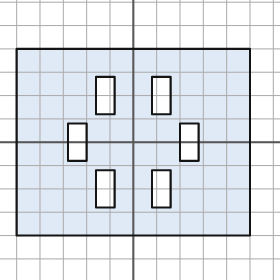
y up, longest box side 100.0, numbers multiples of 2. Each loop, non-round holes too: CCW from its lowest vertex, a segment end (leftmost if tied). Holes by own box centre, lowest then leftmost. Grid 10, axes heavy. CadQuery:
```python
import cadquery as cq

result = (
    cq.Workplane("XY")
    .moveTo(-50.0, -40.0)
    .lineTo(50.0, -40.0)
    .lineTo(50.0, 40.0)
    .lineTo(-50.0, 40.0)
    .close()
    .moveTo(-16.0, -28.0)
    .lineTo(-8.0, -28.0)
    .lineTo(-8.0, -12.0)
    .lineTo(-16.0, -12.0)
    .close()
    .moveTo(8.0, -28.0)
    .lineTo(16.0, -28.0)
    .lineTo(16.0, -12.0)
    .lineTo(8.0, -12.0)
    .close()
    .moveTo(-28.0, -8.0)
    .lineTo(-20.0, -8.0)
    .lineTo(-20.0, 8.0)
    .lineTo(-28.0, 8.0)
    .close()
    .moveTo(20.0, -8.0)
    .lineTo(28.0, -8.0)
    .lineTo(28.0, 8.0)
    .lineTo(20.0, 8.0)
    .close()
    .moveTo(-16.0, 12.0)
    .lineTo(-8.0, 12.0)
    .lineTo(-8.0, 28.0)
    .lineTo(-16.0, 28.0)
    .close()
    .moveTo(8.0, 12.0)
    .lineTo(16.0, 12.0)
    .lineTo(16.0, 28.0)
    .lineTo(8.0, 28.0)
    .close()
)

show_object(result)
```